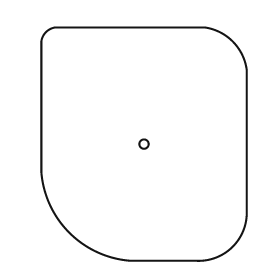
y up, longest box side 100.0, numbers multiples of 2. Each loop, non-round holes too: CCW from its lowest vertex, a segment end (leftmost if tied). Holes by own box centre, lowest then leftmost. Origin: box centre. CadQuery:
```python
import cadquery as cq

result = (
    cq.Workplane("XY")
    .moveTo(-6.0, -50.0)
    .lineTo(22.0, -50.0)
    .threePointArc((38.0, -44.0), (44.0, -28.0))
    .lineTo(44.0, 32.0)
    .threePointArc((38.0, 44.0), (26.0, 50.0))
    .lineTo(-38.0, 50.0)
    .threePointArc((-42.0, 48.0), (-44.0, 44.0))
    .lineTo(-44.0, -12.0)
    .threePointArc((-32.0, -38.0), (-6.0, -50.0))
    .close()
    .moveTo(0.0, 0.0)
    .circle(2.0)
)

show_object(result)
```